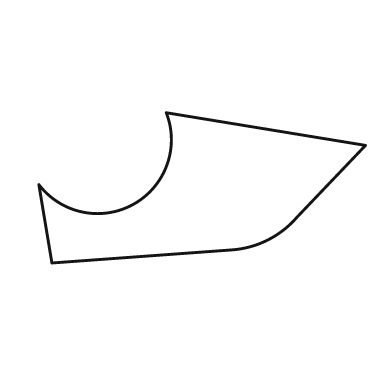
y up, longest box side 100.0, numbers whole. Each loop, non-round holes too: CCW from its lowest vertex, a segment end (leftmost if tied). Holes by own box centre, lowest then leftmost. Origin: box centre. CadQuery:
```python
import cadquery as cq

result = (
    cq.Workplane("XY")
    .moveTo(-46.0, -23.0)
    .lineTo(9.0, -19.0)
    .threePointArc((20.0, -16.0), (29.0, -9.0))
    .lineTo(50.0, 13.0)
    .lineTo(-11.0, 23.0)
    .threePointArc((-21.0, -5.0), (-50.0, 1.0))
    .close()
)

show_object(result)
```